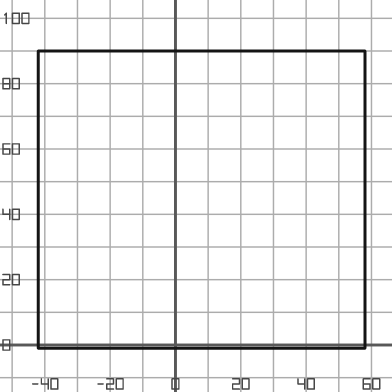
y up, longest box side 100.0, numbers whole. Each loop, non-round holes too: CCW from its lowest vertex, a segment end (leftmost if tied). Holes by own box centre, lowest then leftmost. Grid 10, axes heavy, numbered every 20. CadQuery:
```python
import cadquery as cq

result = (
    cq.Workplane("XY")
    .moveTo(-42.0, -1.0)
    .lineTo(58.0, -1.0)
    .lineTo(58.0, 90.0)
    .lineTo(-42.0, 90.0)
    .close()
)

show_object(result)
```